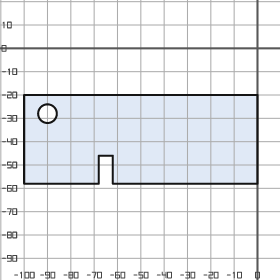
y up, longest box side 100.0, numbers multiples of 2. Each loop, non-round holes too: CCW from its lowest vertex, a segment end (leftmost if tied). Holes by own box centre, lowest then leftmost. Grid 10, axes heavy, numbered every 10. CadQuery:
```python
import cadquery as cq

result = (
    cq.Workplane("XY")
    .moveTo(-100.0, -58.0)
    .lineTo(-68.0, -58.0)
    .lineTo(-68.0, -46.0)
    .lineTo(-62.0, -46.0)
    .lineTo(-62.0, -58.0)
    .lineTo(0.0, -58.0)
    .lineTo(0.0, -20.0)
    .lineTo(-100.0, -20.0)
    .close()
    .moveTo(-90.0, -28.0)
    .circle(4.0)
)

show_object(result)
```